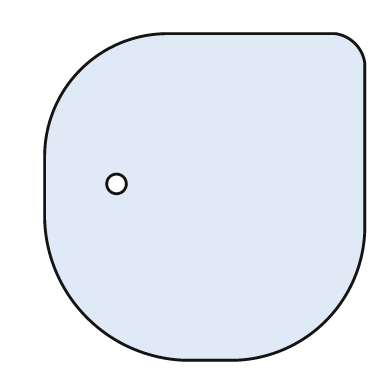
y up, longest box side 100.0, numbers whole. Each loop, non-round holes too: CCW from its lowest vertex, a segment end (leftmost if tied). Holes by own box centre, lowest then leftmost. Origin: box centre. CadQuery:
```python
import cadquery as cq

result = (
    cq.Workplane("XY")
    .moveTo(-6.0, -50.0)
    .lineTo(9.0, -50.0)
    .threePointArc((37.0, -38.0), (49.0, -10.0))
    .lineTo(49.0, 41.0)
    .threePointArc((46.0, 47.0), (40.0, 50.0))
    .lineTo(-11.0, 50.0)
    .threePointArc((-38.0, 39.0), (-49.0, 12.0))
    .lineTo(-49.0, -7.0)
    .threePointArc((-36.0, -37.0), (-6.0, -50.0))
    .close()
    .moveTo(-27.0, 4.0)
    .circle(3.0)
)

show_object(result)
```